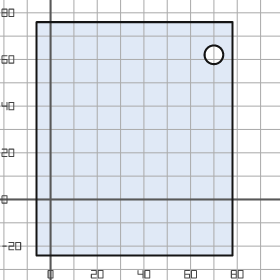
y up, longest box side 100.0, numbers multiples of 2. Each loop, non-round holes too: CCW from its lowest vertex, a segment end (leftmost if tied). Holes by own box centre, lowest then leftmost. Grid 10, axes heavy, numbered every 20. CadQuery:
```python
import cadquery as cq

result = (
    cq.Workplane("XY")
    .moveTo(-6.0, -24.0)
    .lineTo(78.0, -24.0)
    .lineTo(78.0, 76.0)
    .lineTo(-6.0, 76.0)
    .close()
    .moveTo(70.0, 62.0)
    .circle(4.0)
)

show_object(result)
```